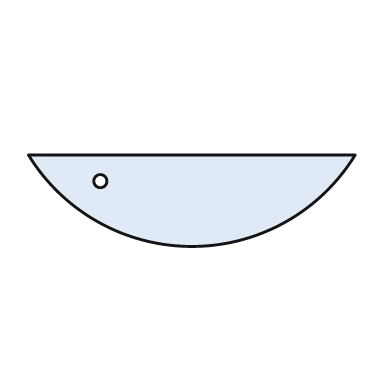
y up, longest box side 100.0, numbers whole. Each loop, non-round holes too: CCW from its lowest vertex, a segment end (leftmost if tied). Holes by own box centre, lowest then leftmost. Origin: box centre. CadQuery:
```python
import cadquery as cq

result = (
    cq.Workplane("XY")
    .moveTo(-50.0, 14.0)
    .threePointArc((0.0, -14.0), (50.0, 14.0))
    .close()
    .moveTo(-28.0, 6.0)
    .circle(2.0)
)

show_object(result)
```